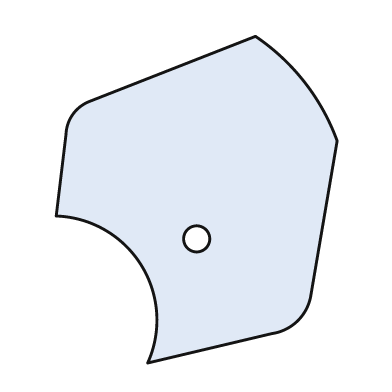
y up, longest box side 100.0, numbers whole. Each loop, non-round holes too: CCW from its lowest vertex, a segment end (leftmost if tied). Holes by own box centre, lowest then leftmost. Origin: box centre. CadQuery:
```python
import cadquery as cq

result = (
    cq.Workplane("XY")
    .moveTo(-15.0, -50.0)
    .lineTo(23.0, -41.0)
    .threePointArc((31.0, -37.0), (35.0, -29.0))
    .lineTo(43.0, 18.0)
    .threePointArc((33.0, 36.0), (18.0, 50.0))
    .lineTo(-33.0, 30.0)
    .threePointArc((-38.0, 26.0), (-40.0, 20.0))
    .lineTo(-43.0, -5.0)
    .threePointArc((-17.0, -20.0), (-15.0, -50.0))
    .close()
    .moveTo(0.0, -12.0)
    .circle(4.0)
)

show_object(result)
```